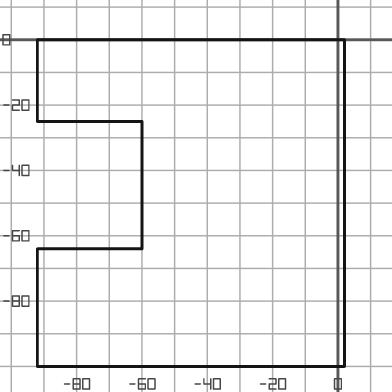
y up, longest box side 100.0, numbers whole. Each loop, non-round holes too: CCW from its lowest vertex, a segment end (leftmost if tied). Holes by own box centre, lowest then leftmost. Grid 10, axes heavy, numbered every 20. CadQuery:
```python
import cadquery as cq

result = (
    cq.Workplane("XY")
    .moveTo(-92.0, -100.0)
    .lineTo(2.0, -100.0)
    .lineTo(2.0, 0.0)
    .lineTo(-92.0, 0.0)
    .lineTo(-92.0, -25.0)
    .lineTo(-60.0, -25.0)
    .lineTo(-60.0, -64.0)
    .lineTo(-92.0, -64.0)
    .close()
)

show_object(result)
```